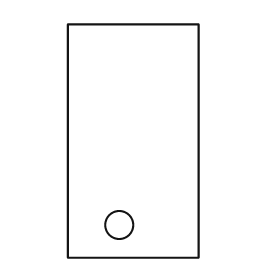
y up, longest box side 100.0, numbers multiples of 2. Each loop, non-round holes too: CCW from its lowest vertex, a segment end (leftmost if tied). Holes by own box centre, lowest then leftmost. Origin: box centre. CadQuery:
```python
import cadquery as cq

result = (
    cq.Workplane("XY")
    .moveTo(-28.0, -50.0)
    .lineTo(28.0, -50.0)
    .lineTo(28.0, 50.0)
    .lineTo(-28.0, 50.0)
    .close()
    .moveTo(-6.0, -36.0)
    .circle(6.0)
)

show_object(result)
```